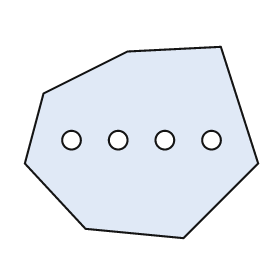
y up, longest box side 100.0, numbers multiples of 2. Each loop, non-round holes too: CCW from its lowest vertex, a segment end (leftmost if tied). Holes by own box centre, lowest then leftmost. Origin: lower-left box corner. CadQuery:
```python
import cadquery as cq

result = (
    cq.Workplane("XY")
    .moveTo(68.0, 0.0)
    .lineTo(100.0, 32.0)
    .lineTo(84.0, 82.0)
    .lineTo(44.0, 80.0)
    .lineTo(8.0, 62.0)
    .lineTo(0.0, 32.0)
    .lineTo(26.0, 4.0)
    .close()
    .moveTo(20.0, 42.0)
    .circle(4.0)
    .moveTo(40.0, 42.0)
    .circle(4.0)
    .moveTo(60.0, 42.0)
    .circle(4.0)
    .moveTo(80.0, 42.0)
    .circle(4.0)
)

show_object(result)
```